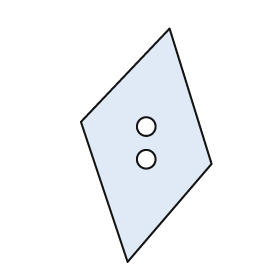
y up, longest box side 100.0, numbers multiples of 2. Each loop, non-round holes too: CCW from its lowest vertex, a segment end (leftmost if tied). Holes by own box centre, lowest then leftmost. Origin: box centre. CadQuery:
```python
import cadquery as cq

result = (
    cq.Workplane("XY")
    .moveTo(-8.0, -50.0)
    .lineTo(28.0, -8.0)
    .lineTo(10.0, 50.0)
    .lineTo(-28.0, 10.0)
    .close()
    .moveTo(0.0, -6.0)
    .circle(4.0)
    .moveTo(0.0, 8.0)
    .circle(4.0)
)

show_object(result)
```